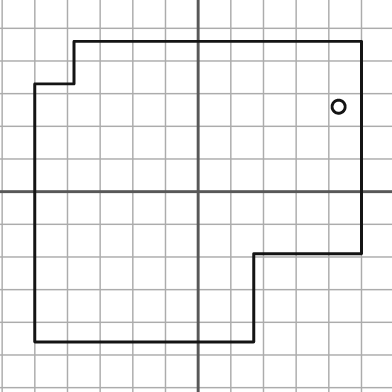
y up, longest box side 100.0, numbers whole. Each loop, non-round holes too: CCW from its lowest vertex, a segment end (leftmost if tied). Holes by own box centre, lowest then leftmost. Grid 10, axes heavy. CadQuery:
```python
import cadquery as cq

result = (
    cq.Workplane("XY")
    .moveTo(-50.0, -46.0)
    .lineTo(17.0, -46.0)
    .lineTo(17.0, -19.0)
    .lineTo(50.0, -19.0)
    .lineTo(50.0, 46.0)
    .lineTo(-38.0, 46.0)
    .lineTo(-38.0, 33.0)
    .lineTo(-50.0, 33.0)
    .close()
    .moveTo(43.0, 26.0)
    .circle(2.0)
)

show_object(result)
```